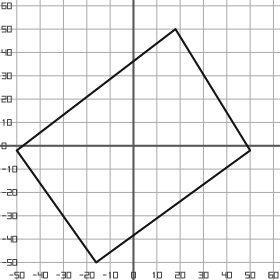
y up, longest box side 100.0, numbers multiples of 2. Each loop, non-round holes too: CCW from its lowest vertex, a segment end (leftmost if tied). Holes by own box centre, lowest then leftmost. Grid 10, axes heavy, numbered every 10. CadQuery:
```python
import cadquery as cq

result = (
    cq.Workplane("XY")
    .moveTo(-16.0, -50.0)
    .lineTo(50.0, -2.0)
    .lineTo(18.0, 50.0)
    .lineTo(-50.0, -2.0)
    .close()
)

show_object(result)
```